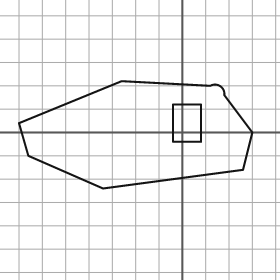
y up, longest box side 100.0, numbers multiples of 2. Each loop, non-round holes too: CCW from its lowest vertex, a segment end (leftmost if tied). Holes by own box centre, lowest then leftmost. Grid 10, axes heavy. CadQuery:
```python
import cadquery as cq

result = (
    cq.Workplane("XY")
    .moveTo(-34.0, -24.0)
    .lineTo(26.0, -16.0)
    .lineTo(30.0, 0.0)
    .lineTo(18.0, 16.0)
    .threePointArc((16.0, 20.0), (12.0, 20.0))
    .lineTo(-26.0, 22.0)
    .lineTo(-70.0, 4.0)
    .lineTo(-66.0, -10.0)
    .close()
    .moveTo(-4.0, -4.0)
    .lineTo(8.0, -4.0)
    .lineTo(8.0, 12.0)
    .lineTo(-4.0, 12.0)
    .close()
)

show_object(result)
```